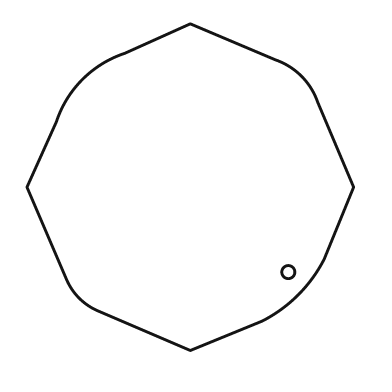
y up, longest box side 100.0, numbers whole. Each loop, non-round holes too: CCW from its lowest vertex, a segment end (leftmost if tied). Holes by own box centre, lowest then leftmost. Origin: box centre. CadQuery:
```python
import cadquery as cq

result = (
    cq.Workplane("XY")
    .moveTo(0.0, -50.0)
    .lineTo(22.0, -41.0)
    .threePointArc((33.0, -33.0), (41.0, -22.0))
    .lineTo(50.0, 0.0)
    .lineTo(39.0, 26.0)
    .threePointArc((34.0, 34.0), (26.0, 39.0))
    .lineTo(0.0, 50.0)
    .lineTo(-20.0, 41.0)
    .threePointArc((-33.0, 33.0), (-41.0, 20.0))
    .lineTo(-50.0, 0.0)
    .lineTo(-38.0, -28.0)
    .threePointArc((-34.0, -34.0), (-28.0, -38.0))
    .close()
    .moveTo(30.0, -26.0)
    .circle(2.0)
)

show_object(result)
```